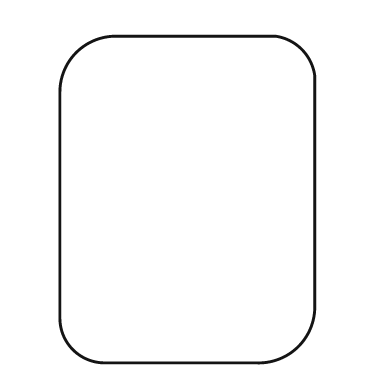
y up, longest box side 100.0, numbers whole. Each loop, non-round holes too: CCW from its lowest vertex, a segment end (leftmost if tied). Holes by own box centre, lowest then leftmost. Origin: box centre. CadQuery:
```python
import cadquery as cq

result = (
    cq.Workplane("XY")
    .moveTo(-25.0, -50.0)
    .lineTo(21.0, -50.0)
    .threePointArc((34.0, -45.0), (39.0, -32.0))
    .lineTo(39.0, 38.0)
    .threePointArc((35.0, 46.0), (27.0, 50.0))
    .lineTo(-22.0, 50.0)
    .threePointArc((-34.0, 45.0), (-39.0, 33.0))
    .lineTo(-39.0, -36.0)
    .threePointArc((-35.0, -46.0), (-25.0, -50.0))
    .close()
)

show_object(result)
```